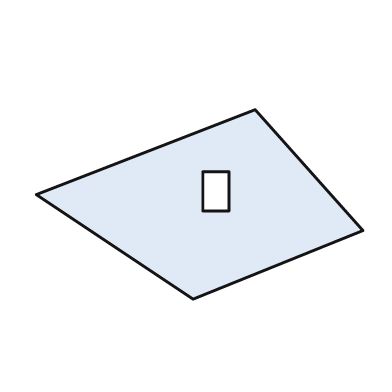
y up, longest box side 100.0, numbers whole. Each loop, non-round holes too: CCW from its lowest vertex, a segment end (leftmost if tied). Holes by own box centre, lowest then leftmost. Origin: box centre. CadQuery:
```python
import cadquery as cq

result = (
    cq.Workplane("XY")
    .moveTo(-2.0, -29.0)
    .lineTo(50.0, -8.0)
    .lineTo(17.0, 29.0)
    .lineTo(-50.0, 3.0)
    .close()
    .moveTo(1.0, -2.0)
    .lineTo(9.0, -2.0)
    .lineTo(9.0, 10.0)
    .lineTo(1.0, 10.0)
    .close()
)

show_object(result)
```